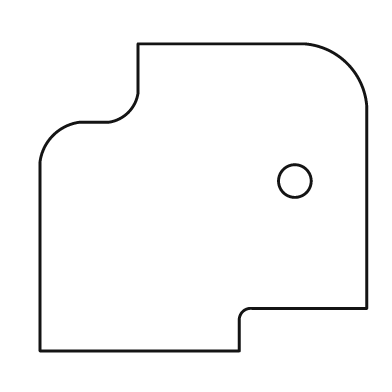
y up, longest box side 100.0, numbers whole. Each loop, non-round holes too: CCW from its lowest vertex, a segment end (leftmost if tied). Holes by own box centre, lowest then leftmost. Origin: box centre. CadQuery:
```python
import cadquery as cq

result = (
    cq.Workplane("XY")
    .moveTo(-50.0, -47.0)
    .lineTo(11.0, -47.0)
    .lineTo(11.0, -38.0)
    .threePointArc((12.0, -35.0), (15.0, -34.0))
    .lineTo(50.0, -34.0)
    .lineTo(50.0, 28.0)
    .threePointArc((44.0, 41.0), (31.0, 47.0))
    .lineTo(-20.0, 47.0)
    .lineTo(-20.0, 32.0)
    .threePointArc((-23.0, 26.0), (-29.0, 23.0))
    .lineTo(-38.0, 23.0)
    .threePointArc((-46.0, 19.0), (-50.0, 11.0))
    .close()
    .moveTo(28.0, 5.0)
    .circle(5.0)
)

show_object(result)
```